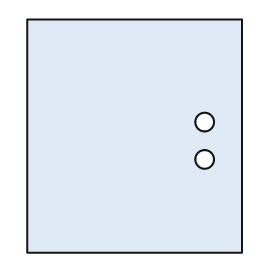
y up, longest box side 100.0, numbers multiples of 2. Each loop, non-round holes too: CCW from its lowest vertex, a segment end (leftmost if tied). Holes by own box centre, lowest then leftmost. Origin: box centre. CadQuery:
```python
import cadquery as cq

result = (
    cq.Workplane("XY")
    .moveTo(-46.0, -50.0)
    .lineTo(46.0, -50.0)
    .lineTo(46.0, 50.0)
    .lineTo(-46.0, 50.0)
    .close()
    .moveTo(30.0, -10.0)
    .circle(4.0)
    .moveTo(30.0, 6.0)
    .circle(4.0)
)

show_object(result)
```